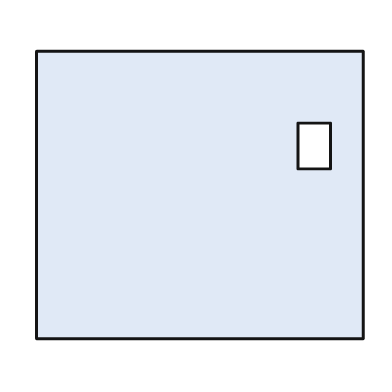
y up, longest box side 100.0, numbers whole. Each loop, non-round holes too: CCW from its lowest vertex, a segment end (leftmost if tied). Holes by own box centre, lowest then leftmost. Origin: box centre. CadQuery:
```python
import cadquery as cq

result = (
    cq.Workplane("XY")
    .moveTo(-50.0, -44.0)
    .lineTo(50.0, -44.0)
    .lineTo(50.0, 44.0)
    .lineTo(-50.0, 44.0)
    .close()
    .moveTo(30.0, 8.0)
    .lineTo(40.0, 8.0)
    .lineTo(40.0, 22.0)
    .lineTo(30.0, 22.0)
    .close()
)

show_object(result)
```